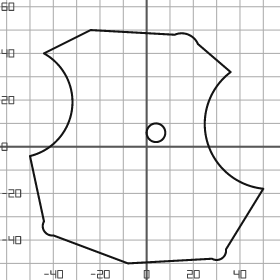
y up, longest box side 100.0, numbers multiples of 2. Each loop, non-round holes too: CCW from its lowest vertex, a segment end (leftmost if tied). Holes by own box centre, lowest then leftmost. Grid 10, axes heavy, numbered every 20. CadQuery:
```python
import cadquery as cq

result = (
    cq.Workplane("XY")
    .moveTo(-8.0, -50.0)
    .lineTo(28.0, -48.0)
    .threePointArc((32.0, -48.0), (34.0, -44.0))
    .lineTo(50.0, -18.0)
    .threePointArc((26.0, 2.0), (36.0, 32.0))
    .lineTo(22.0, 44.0)
    .threePointArc((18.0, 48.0), (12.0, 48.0))
    .lineTo(-24.0, 50.0)
    .lineTo(-44.0, 40.0)
    .threePointArc((-32.0, 16.0), (-50.0, -4.0))
    .lineTo(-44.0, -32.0)
    .threePointArc((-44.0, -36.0), (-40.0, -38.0))
    .close()
    .moveTo(4.0, 6.0)
    .circle(4.0)
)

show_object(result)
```